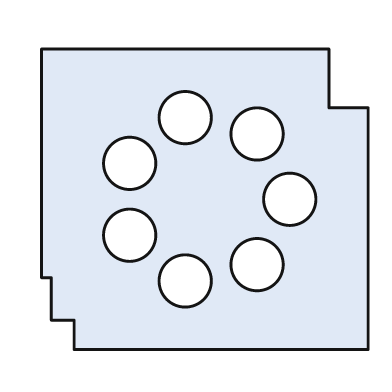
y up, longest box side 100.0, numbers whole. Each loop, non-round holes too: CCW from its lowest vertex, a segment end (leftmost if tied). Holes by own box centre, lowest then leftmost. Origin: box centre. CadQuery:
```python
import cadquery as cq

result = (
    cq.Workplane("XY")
    .moveTo(-40.0, -46.0)
    .lineTo(50.0, -46.0)
    .lineTo(50.0, 28.0)
    .lineTo(38.0, 28.0)
    .lineTo(38.0, 46.0)
    .lineTo(-50.0, 46.0)
    .lineTo(-50.0, -24.0)
    .lineTo(-47.0, -24.0)
    .lineTo(-47.0, -37.0)
    .lineTo(-40.0, -37.0)
    .close()
    .moveTo(-6.0, -25.0)
    .circle(8.0)
    .moveTo(16.0, -20.0)
    .circle(8.0)
    .moveTo(-23.0, -11.0)
    .circle(8.0)
    .moveTo(26.0, 0.0)
    .circle(8.0)
    .moveTo(-23.0, 11.0)
    .circle(8.0)
    .moveTo(16.0, 20.0)
    .circle(8.0)
    .moveTo(-6.0, 25.0)
    .circle(8.0)
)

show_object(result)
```